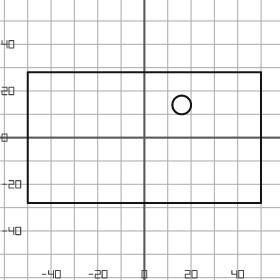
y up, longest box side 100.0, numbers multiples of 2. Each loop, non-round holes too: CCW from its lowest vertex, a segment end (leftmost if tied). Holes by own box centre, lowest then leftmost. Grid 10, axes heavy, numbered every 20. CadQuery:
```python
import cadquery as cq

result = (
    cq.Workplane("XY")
    .moveTo(-50.0, -28.0)
    .lineTo(50.0, -28.0)
    .lineTo(50.0, 28.0)
    .lineTo(-50.0, 28.0)
    .close()
    .moveTo(16.0, 14.0)
    .circle(4.0)
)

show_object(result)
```